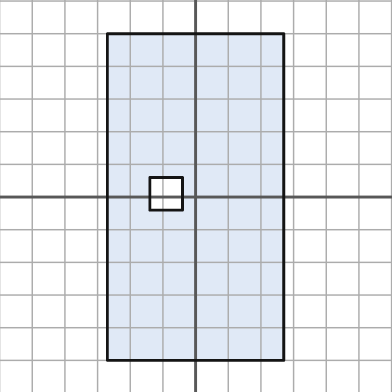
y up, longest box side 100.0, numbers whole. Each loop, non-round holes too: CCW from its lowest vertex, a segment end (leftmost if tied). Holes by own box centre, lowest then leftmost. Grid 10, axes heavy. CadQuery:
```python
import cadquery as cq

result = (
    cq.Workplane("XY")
    .moveTo(-27.0, -50.0)
    .lineTo(27.0, -50.0)
    .lineTo(27.0, 50.0)
    .lineTo(-27.0, 50.0)
    .close()
    .moveTo(-14.0, -4.0)
    .lineTo(-4.0, -4.0)
    .lineTo(-4.0, 6.0)
    .lineTo(-14.0, 6.0)
    .close()
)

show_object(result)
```